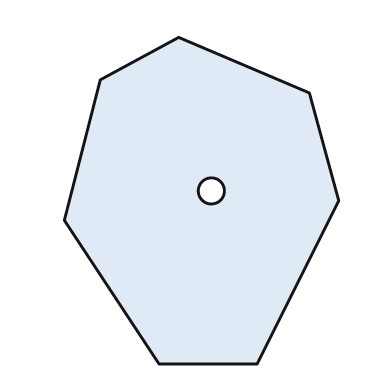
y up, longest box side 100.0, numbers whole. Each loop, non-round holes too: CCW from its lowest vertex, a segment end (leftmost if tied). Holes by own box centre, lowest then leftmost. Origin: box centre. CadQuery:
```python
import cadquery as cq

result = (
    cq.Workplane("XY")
    .moveTo(-13.0, -50.0)
    .lineTo(17.0, -50.0)
    .lineTo(42.0, 0.0)
    .lineTo(33.0, 33.0)
    .lineTo(-7.0, 50.0)
    .lineTo(-31.0, 37.0)
    .lineTo(-42.0, -6.0)
    .close()
    .moveTo(3.0, 3.0)
    .circle(4.0)
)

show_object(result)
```